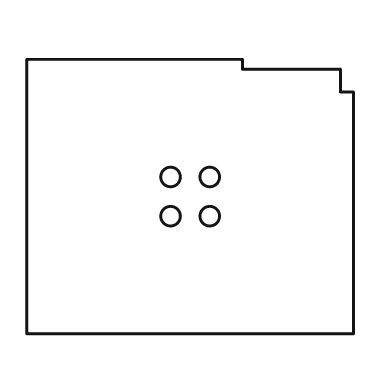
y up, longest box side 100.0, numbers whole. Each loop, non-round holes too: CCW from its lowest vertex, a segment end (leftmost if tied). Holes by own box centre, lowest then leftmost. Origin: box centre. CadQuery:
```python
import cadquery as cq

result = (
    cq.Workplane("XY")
    .moveTo(-50.0, -42.0)
    .lineTo(50.0, -42.0)
    .lineTo(50.0, 32.0)
    .lineTo(46.0, 32.0)
    .lineTo(46.0, 39.0)
    .lineTo(16.0, 39.0)
    .lineTo(16.0, 42.0)
    .lineTo(-50.0, 42.0)
    .close()
    .moveTo(-6.0, -6.0)
    .circle(3.0)
    .moveTo(6.0, -6.0)
    .circle(3.0)
    .moveTo(-6.0, 6.0)
    .circle(3.0)
    .moveTo(6.0, 6.0)
    .circle(3.0)
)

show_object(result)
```